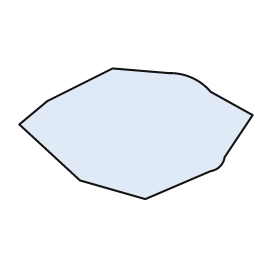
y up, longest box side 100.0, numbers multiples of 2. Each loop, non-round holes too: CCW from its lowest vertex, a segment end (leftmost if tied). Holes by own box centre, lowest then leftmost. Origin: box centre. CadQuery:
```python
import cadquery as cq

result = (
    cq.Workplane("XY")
    .moveTo(4.0, -28.0)
    .lineTo(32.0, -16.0)
    .threePointArc((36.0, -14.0), (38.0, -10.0))
    .lineTo(50.0, 8.0)
    .lineTo(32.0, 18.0)
    .threePointArc((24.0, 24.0), (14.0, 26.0))
    .lineTo(-10.0, 28.0)
    .lineTo(-38.0, 14.0)
    .lineTo(-50.0, 4.0)
    .lineTo(-24.0, -20.0)
    .close()
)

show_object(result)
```